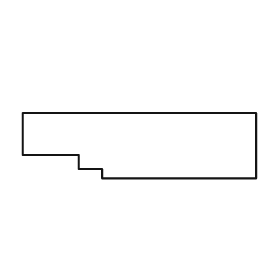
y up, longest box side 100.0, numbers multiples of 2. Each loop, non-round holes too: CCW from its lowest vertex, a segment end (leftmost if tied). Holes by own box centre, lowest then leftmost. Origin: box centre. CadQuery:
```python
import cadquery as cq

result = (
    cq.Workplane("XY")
    .moveTo(-16.0, -14.0)
    .lineTo(50.0, -14.0)
    .lineTo(50.0, 14.0)
    .lineTo(-50.0, 14.0)
    .lineTo(-50.0, -4.0)
    .lineTo(-26.0, -4.0)
    .lineTo(-26.0, -10.0)
    .lineTo(-16.0, -10.0)
    .close()
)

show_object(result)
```